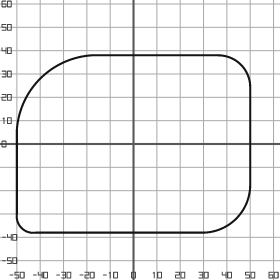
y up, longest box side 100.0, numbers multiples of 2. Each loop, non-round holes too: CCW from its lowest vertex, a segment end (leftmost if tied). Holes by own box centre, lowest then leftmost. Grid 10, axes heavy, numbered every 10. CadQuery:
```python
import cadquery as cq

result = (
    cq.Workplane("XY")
    .moveTo(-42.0, -38.0)
    .lineTo(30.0, -38.0)
    .threePointArc((44.0, -32.0), (50.0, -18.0))
    .lineTo(50.0, 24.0)
    .threePointArc((46.0, 34.0), (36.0, 38.0))
    .lineTo(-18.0, 38.0)
    .threePointArc((-40.0, 28.0), (-50.0, 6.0))
    .lineTo(-50.0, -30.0)
    .threePointArc((-48.0, -36.0), (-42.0, -38.0))
    .close()
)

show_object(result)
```